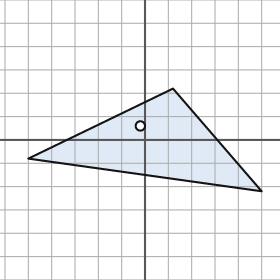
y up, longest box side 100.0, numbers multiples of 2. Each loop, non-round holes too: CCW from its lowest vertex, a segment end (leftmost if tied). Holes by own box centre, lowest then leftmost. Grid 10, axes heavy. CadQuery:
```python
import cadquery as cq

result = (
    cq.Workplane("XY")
    .moveTo(50.0, -22.0)
    .lineTo(12.0, 22.0)
    .lineTo(-50.0, -8.0)
    .close()
    .moveTo(-2.0, 6.0)
    .circle(2.0)
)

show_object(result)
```